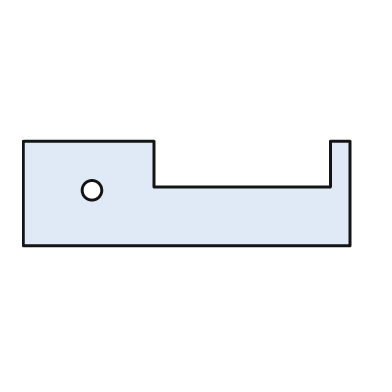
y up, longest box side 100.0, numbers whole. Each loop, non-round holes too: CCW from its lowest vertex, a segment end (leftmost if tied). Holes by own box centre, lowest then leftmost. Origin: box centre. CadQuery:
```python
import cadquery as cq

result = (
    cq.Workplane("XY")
    .moveTo(-50.0, -16.0)
    .lineTo(50.0, -16.0)
    .lineTo(50.0, 16.0)
    .lineTo(44.0, 16.0)
    .lineTo(44.0, 2.0)
    .lineTo(-10.0, 2.0)
    .lineTo(-10.0, 16.0)
    .lineTo(-50.0, 16.0)
    .close()
    .moveTo(-29.0, 1.0)
    .circle(3.0)
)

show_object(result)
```